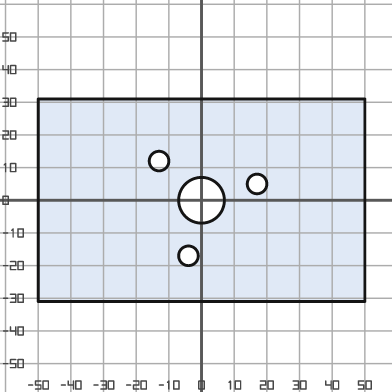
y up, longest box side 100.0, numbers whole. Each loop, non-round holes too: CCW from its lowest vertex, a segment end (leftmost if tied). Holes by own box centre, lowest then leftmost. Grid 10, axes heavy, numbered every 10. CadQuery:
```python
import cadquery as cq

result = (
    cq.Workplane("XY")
    .moveTo(-50.0, -31.0)
    .lineTo(50.0, -31.0)
    .lineTo(50.0, 31.0)
    .lineTo(-50.0, 31.0)
    .close()
    .moveTo(-4.0, -17.0)
    .circle(3.0)
    .moveTo(0.0, 0.0)
    .circle(7.0)
    .moveTo(17.0, 5.0)
    .circle(3.0)
    .moveTo(-13.0, 12.0)
    .circle(3.0)
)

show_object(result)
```